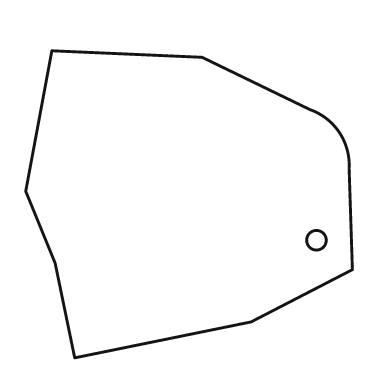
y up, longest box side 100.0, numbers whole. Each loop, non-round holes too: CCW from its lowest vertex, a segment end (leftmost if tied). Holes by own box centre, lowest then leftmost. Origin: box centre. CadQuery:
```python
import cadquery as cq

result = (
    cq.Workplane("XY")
    .moveTo(-35.0, -47.0)
    .lineTo(19.0, -36.0)
    .lineTo(50.0, -20.0)
    .lineTo(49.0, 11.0)
    .threePointArc((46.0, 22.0), (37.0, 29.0))
    .lineTo(4.0, 45.0)
    .lineTo(-42.0, 47.0)
    .lineTo(-50.0, 4.0)
    .lineTo(-41.0, -18.0)
    .close()
    .moveTo(39.0, -11.0)
    .circle(3.0)
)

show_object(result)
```